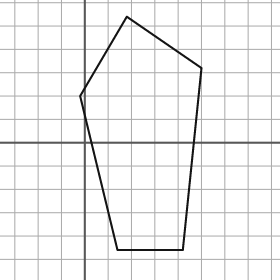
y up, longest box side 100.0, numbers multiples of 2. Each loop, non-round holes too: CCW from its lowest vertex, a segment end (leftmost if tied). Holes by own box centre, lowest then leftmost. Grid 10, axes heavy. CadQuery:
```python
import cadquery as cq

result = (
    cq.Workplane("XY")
    .moveTo(14.0, -46.0)
    .lineTo(42.0, -46.0)
    .lineTo(50.0, 32.0)
    .lineTo(18.0, 54.0)
    .lineTo(-2.0, 20.0)
    .close()
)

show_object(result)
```